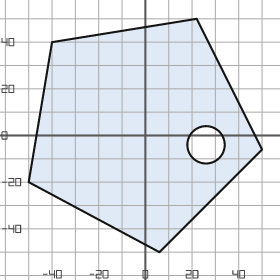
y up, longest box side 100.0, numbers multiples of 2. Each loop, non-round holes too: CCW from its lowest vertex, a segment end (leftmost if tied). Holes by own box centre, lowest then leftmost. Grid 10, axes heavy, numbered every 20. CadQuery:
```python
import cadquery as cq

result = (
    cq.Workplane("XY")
    .moveTo(6.0, -50.0)
    .lineTo(50.0, -6.0)
    .lineTo(22.0, 50.0)
    .lineTo(-40.0, 40.0)
    .lineTo(-50.0, -20.0)
    .close()
    .moveTo(26.0, -4.0)
    .circle(8.0)
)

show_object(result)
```